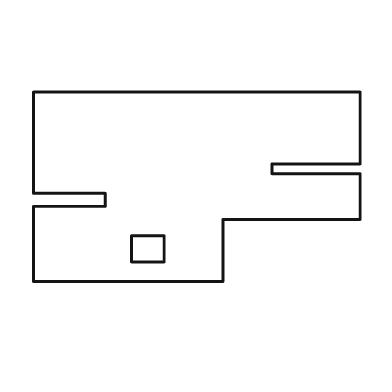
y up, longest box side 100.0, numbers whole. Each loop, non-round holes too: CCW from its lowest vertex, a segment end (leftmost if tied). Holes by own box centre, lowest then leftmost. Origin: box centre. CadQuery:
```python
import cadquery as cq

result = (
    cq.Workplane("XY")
    .moveTo(-50.0, -29.0)
    .lineTo(8.0, -29.0)
    .lineTo(8.0, -10.0)
    .lineTo(50.0, -10.0)
    .lineTo(50.0, 4.0)
    .lineTo(23.0, 4.0)
    .lineTo(23.0, 7.0)
    .lineTo(50.0, 7.0)
    .lineTo(50.0, 29.0)
    .lineTo(-50.0, 29.0)
    .lineTo(-50.0, -2.0)
    .lineTo(-28.0, -2.0)
    .lineTo(-28.0, -6.0)
    .lineTo(-50.0, -6.0)
    .close()
    .moveTo(-20.0, -23.0)
    .lineTo(-10.0, -23.0)
    .lineTo(-10.0, -15.0)
    .lineTo(-20.0, -15.0)
    .close()
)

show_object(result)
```